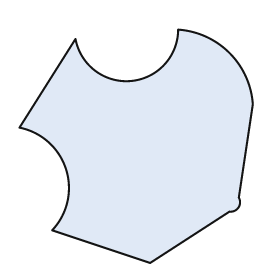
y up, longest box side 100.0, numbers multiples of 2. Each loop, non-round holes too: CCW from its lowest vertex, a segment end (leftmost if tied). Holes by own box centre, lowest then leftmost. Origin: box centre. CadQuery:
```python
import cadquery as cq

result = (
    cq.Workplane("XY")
    .moveTo(6.0, -50.0)
    .lineTo(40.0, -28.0)
    .threePointArc((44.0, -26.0), (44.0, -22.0))
    .lineTo(50.0, 18.0)
    .threePointArc((40.0, 40.0), (18.0, 50.0))
    .threePointArc((-2.0, 28.0), (-26.0, 46.0))
    .lineTo(-50.0, 8.0)
    .threePointArc((-30.0, -10.0), (-36.0, -36.0))
    .close()
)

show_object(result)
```